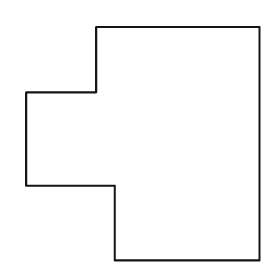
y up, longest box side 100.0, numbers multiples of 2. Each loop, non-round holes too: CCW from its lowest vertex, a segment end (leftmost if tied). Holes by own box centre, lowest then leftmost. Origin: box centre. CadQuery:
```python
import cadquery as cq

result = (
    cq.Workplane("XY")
    .moveTo(-12.0, -50.0)
    .lineTo(50.0, -50.0)
    .lineTo(50.0, 50.0)
    .lineTo(-20.0, 50.0)
    .lineTo(-20.0, 22.0)
    .lineTo(-50.0, 22.0)
    .lineTo(-50.0, -18.0)
    .lineTo(-12.0, -18.0)
    .close()
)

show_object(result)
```